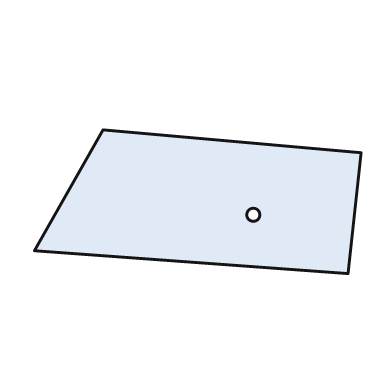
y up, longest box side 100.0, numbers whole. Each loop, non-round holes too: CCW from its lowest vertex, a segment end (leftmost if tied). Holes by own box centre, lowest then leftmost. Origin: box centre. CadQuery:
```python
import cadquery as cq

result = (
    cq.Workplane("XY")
    .moveTo(46.0, -22.0)
    .lineTo(50.0, 15.0)
    .lineTo(-29.0, 22.0)
    .lineTo(-50.0, -15.0)
    .close()
    .moveTo(17.0, -4.0)
    .circle(2.0)
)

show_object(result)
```